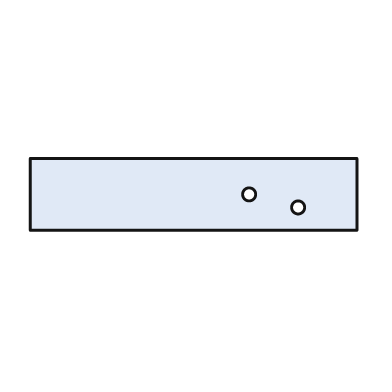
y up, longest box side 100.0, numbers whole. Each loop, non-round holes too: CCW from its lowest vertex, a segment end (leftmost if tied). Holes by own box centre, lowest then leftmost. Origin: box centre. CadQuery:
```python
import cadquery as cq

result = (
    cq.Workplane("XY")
    .moveTo(-50.0, -11.0)
    .lineTo(50.0, -11.0)
    .lineTo(50.0, 11.0)
    .lineTo(-50.0, 11.0)
    .close()
    .moveTo(32.0, -4.0)
    .circle(2.0)
    .moveTo(17.0, 0.0)
    .circle(2.0)
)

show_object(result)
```